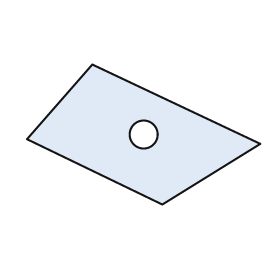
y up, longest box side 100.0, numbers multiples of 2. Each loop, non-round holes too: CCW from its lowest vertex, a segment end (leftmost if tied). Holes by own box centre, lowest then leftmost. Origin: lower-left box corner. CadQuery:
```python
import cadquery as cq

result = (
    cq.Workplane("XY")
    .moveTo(58.0, 0.0)
    .lineTo(100.0, 26.0)
    .lineTo(28.0, 60.0)
    .lineTo(0.0, 28.0)
    .close()
    .moveTo(50.0, 30.0)
    .circle(6.0)
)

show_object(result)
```